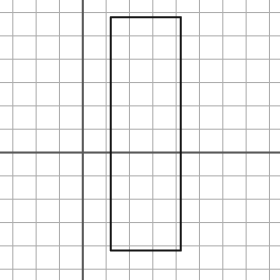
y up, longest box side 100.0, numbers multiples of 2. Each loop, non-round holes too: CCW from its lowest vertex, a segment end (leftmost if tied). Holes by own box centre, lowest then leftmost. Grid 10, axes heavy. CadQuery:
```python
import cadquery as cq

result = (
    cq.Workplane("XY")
    .moveTo(12.0, -42.0)
    .lineTo(42.0, -42.0)
    .lineTo(42.0, 58.0)
    .lineTo(12.0, 58.0)
    .close()
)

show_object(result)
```